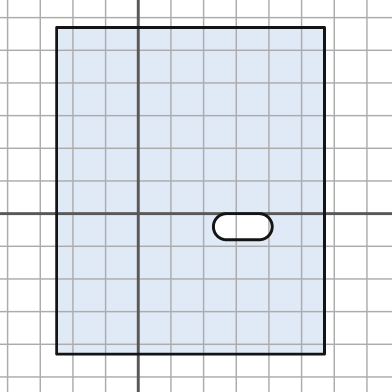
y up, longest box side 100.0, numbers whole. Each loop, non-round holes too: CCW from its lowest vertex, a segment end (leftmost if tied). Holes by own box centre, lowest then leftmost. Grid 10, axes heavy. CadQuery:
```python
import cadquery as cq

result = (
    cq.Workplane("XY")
    .moveTo(-25.0, -43.0)
    .lineTo(57.0, -43.0)
    .lineTo(57.0, 57.0)
    .lineTo(-25.0, 57.0)
    .close()
    .moveTo(27.0, -8.0)
    .lineTo(37.0, -8.0)
    .threePointArc((41.0, -4.0), (37.0, 0.0))
    .lineTo(27.0, 0.0)
    .threePointArc((23.0, -4.0), (27.0, -8.0))
    .close()
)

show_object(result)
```